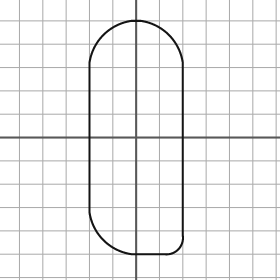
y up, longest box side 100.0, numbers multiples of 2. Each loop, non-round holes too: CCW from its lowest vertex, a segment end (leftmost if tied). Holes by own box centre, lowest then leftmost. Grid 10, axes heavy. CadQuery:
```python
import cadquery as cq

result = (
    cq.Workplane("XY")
    .moveTo(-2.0, -50.0)
    .lineTo(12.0, -50.0)
    .threePointArc((18.0, -48.0), (20.0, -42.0))
    .lineTo(20.0, 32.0)
    .threePointArc((14.0, 44.0), (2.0, 50.0))
    .lineTo(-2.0, 50.0)
    .threePointArc((-14.0, 44.0), (-20.0, 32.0))
    .lineTo(-20.0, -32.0)
    .threePointArc((-14.0, -44.0), (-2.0, -50.0))
    .close()
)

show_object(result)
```